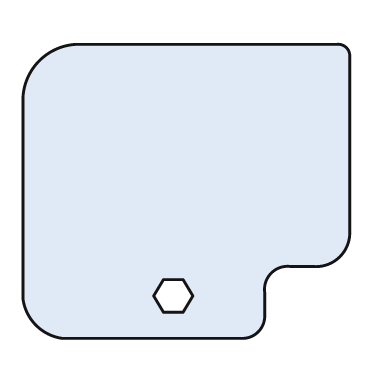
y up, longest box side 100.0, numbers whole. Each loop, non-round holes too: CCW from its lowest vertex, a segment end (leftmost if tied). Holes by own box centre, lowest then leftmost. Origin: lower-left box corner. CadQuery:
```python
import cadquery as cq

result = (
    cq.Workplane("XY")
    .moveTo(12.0, 0.0)
    .lineTo(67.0, 0.0)
    .threePointArc((72.0, 2.0), (74.0, 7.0))
    .lineTo(74.0, 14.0)
    .threePointArc((76.0, 20.0), (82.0, 22.0))
    .lineTo(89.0, 22.0)
    .threePointArc((97.0, 25.0), (100.0, 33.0))
    .lineTo(100.0, 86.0)
    .threePointArc((99.0, 89.0), (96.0, 90.0))
    .lineTo(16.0, 90.0)
    .threePointArc((5.0, 85.0), (0.0, 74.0))
    .lineTo(0.0, 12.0)
    .threePointArc((4.0, 4.0), (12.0, 0.0))
    .close()
    .moveTo(43.0, 8.0)
    .lineTo(49.0, 8.0)
    .lineTo(52.0, 13.0)
    .lineTo(49.0, 18.0)
    .lineTo(43.0, 18.0)
    .lineTo(40.0, 13.0)
    .close()
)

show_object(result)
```